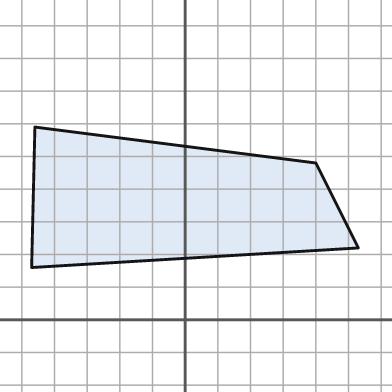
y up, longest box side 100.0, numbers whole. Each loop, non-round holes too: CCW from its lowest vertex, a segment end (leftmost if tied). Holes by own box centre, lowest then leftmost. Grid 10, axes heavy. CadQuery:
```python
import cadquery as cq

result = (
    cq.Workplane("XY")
    .moveTo(-47.0, 16.0)
    .lineTo(53.0, 22.0)
    .lineTo(40.0, 48.0)
    .lineTo(-46.0, 59.0)
    .close()
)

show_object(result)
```